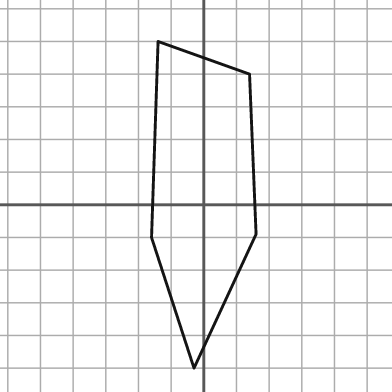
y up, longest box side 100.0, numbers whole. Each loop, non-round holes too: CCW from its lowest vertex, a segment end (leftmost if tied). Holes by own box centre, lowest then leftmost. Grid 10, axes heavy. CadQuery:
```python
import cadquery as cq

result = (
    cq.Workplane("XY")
    .moveTo(-3.0, -50.0)
    .lineTo(16.0, -9.0)
    .lineTo(14.0, 40.0)
    .lineTo(-14.0, 50.0)
    .lineTo(-16.0, -10.0)
    .close()
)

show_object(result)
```